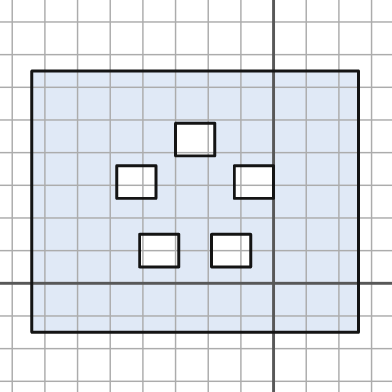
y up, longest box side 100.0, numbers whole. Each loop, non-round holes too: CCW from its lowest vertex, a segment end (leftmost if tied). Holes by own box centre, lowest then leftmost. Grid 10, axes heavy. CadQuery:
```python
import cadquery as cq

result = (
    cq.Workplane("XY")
    .moveTo(-74.0, -15.0)
    .lineTo(26.0, -15.0)
    .lineTo(26.0, 65.0)
    .lineTo(-74.0, 65.0)
    .close()
    .moveTo(-41.0, 5.0)
    .lineTo(-29.0, 5.0)
    .lineTo(-29.0, 15.0)
    .lineTo(-41.0, 15.0)
    .close()
    .moveTo(-19.0, 5.0)
    .lineTo(-7.0, 5.0)
    .lineTo(-7.0, 15.0)
    .lineTo(-19.0, 15.0)
    .close()
    .moveTo(-48.0, 26.0)
    .lineTo(-36.0, 26.0)
    .lineTo(-36.0, 36.0)
    .lineTo(-48.0, 36.0)
    .close()
    .moveTo(-12.0, 26.0)
    .lineTo(0.0, 26.0)
    .lineTo(0.0, 36.0)
    .lineTo(-12.0, 36.0)
    .close()
    .moveTo(-30.0, 39.0)
    .lineTo(-18.0, 39.0)
    .lineTo(-18.0, 49.0)
    .lineTo(-30.0, 49.0)
    .close()
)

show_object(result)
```